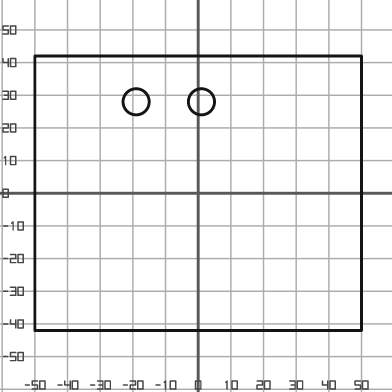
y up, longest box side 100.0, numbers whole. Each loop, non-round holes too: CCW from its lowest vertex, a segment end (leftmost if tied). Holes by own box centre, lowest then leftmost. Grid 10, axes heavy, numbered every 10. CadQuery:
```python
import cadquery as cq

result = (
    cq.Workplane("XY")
    .moveTo(-50.0, -42.0)
    .lineTo(50.0, -42.0)
    .lineTo(50.0, 42.0)
    .lineTo(-50.0, 42.0)
    .close()
    .moveTo(-19.0, 28.0)
    .circle(4.0)
    .moveTo(1.0, 28.0)
    .circle(4.0)
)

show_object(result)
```